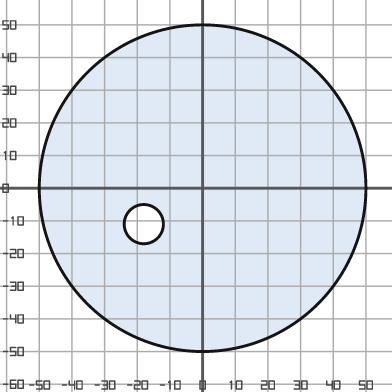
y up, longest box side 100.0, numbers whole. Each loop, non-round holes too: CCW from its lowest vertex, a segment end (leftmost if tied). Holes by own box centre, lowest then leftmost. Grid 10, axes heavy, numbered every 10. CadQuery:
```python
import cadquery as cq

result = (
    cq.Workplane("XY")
    .moveTo(0.0, 0.0)
    .circle(50.0)
    .moveTo(-18.0, -11.0)
    .circle(6.0)
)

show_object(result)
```